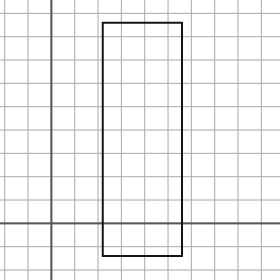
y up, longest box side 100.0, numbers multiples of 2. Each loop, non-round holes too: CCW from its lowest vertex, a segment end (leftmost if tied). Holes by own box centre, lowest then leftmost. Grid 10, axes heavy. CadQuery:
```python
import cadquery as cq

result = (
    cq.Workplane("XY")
    .moveTo(22.0, -14.0)
    .lineTo(56.0, -14.0)
    .lineTo(56.0, 86.0)
    .lineTo(22.0, 86.0)
    .close()
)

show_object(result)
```